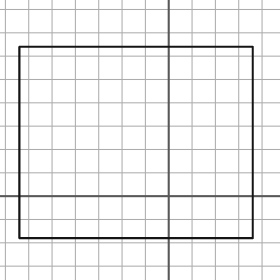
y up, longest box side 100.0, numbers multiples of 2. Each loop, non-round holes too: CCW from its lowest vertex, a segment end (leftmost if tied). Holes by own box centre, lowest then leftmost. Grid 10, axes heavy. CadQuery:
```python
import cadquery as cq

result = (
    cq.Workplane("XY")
    .moveTo(-64.0, -18.0)
    .lineTo(36.0, -18.0)
    .lineTo(36.0, 64.0)
    .lineTo(-64.0, 64.0)
    .close()
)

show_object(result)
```